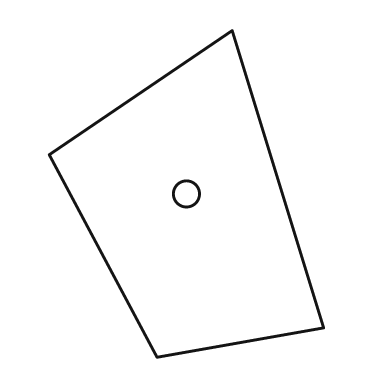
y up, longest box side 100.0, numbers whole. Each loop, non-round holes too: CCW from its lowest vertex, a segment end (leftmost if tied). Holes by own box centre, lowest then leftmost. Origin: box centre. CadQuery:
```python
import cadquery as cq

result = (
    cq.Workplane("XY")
    .moveTo(-9.0, -50.0)
    .lineTo(42.0, -41.0)
    .lineTo(14.0, 50.0)
    .lineTo(-42.0, 12.0)
    .close()
    .moveTo(0.0, 0.0)
    .circle(4.0)
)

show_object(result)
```